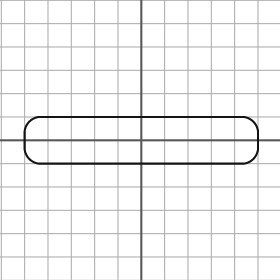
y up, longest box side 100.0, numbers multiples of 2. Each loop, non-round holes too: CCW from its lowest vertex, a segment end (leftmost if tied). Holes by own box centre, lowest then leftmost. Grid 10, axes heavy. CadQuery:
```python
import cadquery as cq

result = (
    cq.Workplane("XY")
    .moveTo(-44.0, -10.0)
    .lineTo(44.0, -10.0)
    .threePointArc((48.0, -8.0), (50.0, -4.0))
    .lineTo(50.0, 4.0)
    .threePointArc((48.0, 8.0), (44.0, 10.0))
    .lineTo(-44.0, 10.0)
    .threePointArc((-48.0, 8.0), (-50.0, 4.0))
    .lineTo(-50.0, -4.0)
    .threePointArc((-48.0, -8.0), (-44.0, -10.0))
    .close()
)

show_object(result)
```